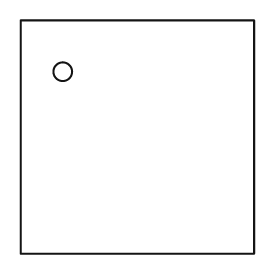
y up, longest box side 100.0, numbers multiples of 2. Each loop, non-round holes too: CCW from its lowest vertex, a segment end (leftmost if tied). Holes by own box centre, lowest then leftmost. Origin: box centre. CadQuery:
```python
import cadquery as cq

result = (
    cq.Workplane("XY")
    .moveTo(-50.0, -50.0)
    .lineTo(50.0, -50.0)
    .lineTo(50.0, 50.0)
    .lineTo(-50.0, 50.0)
    .close()
    .moveTo(-32.0, 28.0)
    .circle(4.0)
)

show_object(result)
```